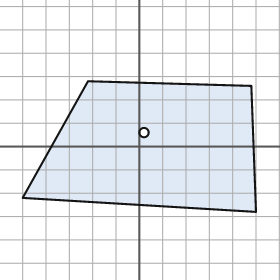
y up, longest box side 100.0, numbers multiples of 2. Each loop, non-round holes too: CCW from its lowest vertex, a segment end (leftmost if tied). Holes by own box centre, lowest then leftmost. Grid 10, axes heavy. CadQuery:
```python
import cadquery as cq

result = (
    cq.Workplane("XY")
    .moveTo(50.0, -28.0)
    .lineTo(48.0, 26.0)
    .lineTo(-22.0, 28.0)
    .lineTo(-50.0, -22.0)
    .close()
    .moveTo(2.0, 6.0)
    .circle(2.0)
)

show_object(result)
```